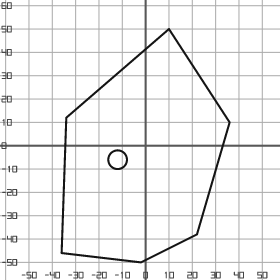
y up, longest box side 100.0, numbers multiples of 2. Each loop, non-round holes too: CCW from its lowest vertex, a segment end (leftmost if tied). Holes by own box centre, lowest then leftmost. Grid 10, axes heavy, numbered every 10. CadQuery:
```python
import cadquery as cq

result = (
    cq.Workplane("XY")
    .moveTo(-2.0, -50.0)
    .lineTo(22.0, -38.0)
    .lineTo(36.0, 10.0)
    .lineTo(10.0, 50.0)
    .lineTo(-34.0, 12.0)
    .lineTo(-36.0, -46.0)
    .close()
    .moveTo(-12.0, -6.0)
    .circle(4.0)
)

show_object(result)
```